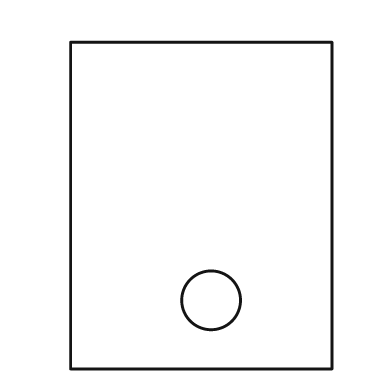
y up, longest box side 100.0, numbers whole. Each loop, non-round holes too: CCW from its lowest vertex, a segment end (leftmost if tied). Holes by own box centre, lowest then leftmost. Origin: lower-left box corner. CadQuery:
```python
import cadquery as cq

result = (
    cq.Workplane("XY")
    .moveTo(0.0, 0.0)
    .lineTo(80.0, 0.0)
    .lineTo(80.0, 100.0)
    .lineTo(0.0, 100.0)
    .close()
    .moveTo(43.0, 21.0)
    .circle(9.0)
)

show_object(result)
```